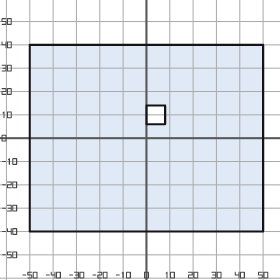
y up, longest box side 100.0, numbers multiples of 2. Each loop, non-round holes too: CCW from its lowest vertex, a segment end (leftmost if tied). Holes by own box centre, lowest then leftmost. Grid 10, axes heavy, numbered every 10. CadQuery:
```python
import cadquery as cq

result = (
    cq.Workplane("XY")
    .moveTo(-50.0, -40.0)
    .lineTo(50.0, -40.0)
    .lineTo(50.0, 40.0)
    .lineTo(-50.0, 40.0)
    .close()
    .moveTo(0.0, 6.0)
    .lineTo(8.0, 6.0)
    .lineTo(8.0, 14.0)
    .lineTo(0.0, 14.0)
    .close()
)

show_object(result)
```